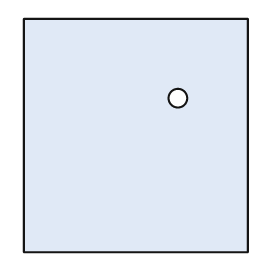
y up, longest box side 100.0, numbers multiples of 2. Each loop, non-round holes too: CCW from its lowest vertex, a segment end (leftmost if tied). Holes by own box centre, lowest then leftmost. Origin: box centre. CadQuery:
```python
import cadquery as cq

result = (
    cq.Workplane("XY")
    .moveTo(-48.0, -50.0)
    .lineTo(48.0, -50.0)
    .lineTo(48.0, 50.0)
    .lineTo(-48.0, 50.0)
    .close()
    .moveTo(18.0, 16.0)
    .circle(4.0)
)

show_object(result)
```